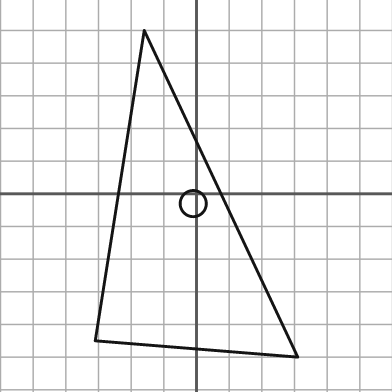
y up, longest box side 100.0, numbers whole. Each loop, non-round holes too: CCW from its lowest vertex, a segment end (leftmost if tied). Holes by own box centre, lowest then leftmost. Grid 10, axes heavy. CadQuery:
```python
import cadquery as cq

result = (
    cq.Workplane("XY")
    .moveTo(31.0, -50.0)
    .lineTo(-16.0, 50.0)
    .lineTo(-31.0, -45.0)
    .close()
    .moveTo(-1.0, -3.0)
    .circle(4.0)
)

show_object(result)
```